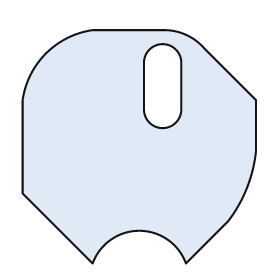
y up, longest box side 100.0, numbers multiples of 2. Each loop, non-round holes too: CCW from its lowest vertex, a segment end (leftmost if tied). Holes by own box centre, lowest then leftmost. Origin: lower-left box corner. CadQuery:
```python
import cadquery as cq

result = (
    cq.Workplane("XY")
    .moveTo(30.0, 0.0)
    .threePointArc((50.0, 14.0), (70.0, 0.0))
    .lineTo(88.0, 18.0)
    .threePointArc((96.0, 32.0), (100.0, 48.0))
    .lineTo(100.0, 70.0)
    .lineTo(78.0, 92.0)
    .threePointArc((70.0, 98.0), (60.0, 100.0))
    .lineTo(30.0, 100.0)
    .threePointArc((10.0, 90.0), (0.0, 70.0))
    .lineTo(0.0, 30.0)
    .close()
    .moveTo(52.0, 66.0)
    .threePointArc((60.0, 58.0), (68.0, 66.0))
    .lineTo(68.0, 86.0)
    .threePointArc((60.0, 94.0), (52.0, 86.0))
    .close()
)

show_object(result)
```